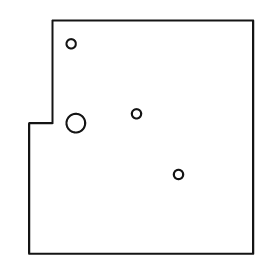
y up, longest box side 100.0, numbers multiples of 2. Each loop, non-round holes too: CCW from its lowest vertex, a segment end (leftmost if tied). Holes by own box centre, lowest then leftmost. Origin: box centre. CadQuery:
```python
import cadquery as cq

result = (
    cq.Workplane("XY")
    .moveTo(-48.0, -50.0)
    .lineTo(48.0, -50.0)
    .lineTo(48.0, 50.0)
    .lineTo(-38.0, 50.0)
    .lineTo(-38.0, 6.0)
    .lineTo(-48.0, 6.0)
    .close()
    .moveTo(16.0, -16.0)
    .circle(2.0)
    .moveTo(-28.0, 6.0)
    .circle(4.0)
    .moveTo(-2.0, 10.0)
    .circle(2.0)
    .moveTo(-30.0, 40.0)
    .circle(2.0)
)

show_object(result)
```